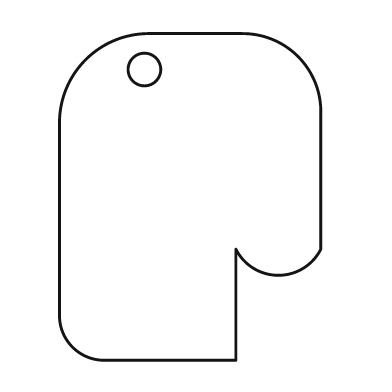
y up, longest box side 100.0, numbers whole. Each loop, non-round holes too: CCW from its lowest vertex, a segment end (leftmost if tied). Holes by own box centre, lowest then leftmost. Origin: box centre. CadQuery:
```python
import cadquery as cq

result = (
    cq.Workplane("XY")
    .moveTo(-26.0, -50.0)
    .lineTo(14.0, -50.0)
    .lineTo(14.0, -16.0)
    .threePointArc((27.0, -24.0), (40.0, -16.0))
    .lineTo(40.0, 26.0)
    .threePointArc((33.0, 43.0), (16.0, 50.0))
    .lineTo(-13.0, 50.0)
    .threePointArc((-32.0, 42.0), (-40.0, 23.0))
    .lineTo(-40.0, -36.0)
    .threePointArc((-36.0, -46.0), (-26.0, -50.0))
    .close()
    .moveTo(-14.0, 39.0)
    .circle(5.0)
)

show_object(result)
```